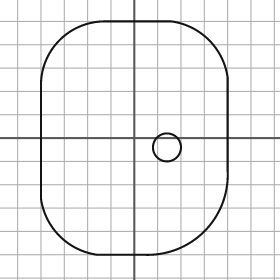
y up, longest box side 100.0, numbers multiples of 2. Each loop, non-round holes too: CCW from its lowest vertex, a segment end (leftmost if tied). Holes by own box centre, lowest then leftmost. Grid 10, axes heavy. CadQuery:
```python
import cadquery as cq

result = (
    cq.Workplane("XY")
    .moveTo(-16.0, -50.0)
    .lineTo(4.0, -50.0)
    .threePointArc((30.0, -40.0), (40.0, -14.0))
    .lineTo(40.0, 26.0)
    .threePointArc((32.0, 42.0), (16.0, 50.0))
    .lineTo(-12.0, 50.0)
    .threePointArc((-32.0, 42.0), (-40.0, 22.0))
    .lineTo(-40.0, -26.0)
    .threePointArc((-32.0, -42.0), (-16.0, -50.0))
    .close()
    .moveTo(14.0, -4.0)
    .circle(6.0)
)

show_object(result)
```